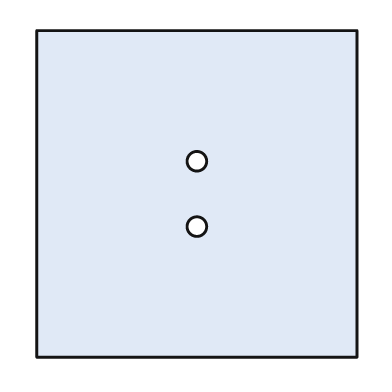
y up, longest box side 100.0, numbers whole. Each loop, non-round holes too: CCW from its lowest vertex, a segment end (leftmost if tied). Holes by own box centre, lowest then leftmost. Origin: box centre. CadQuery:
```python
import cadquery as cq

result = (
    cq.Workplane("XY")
    .moveTo(-49.0, -50.0)
    .lineTo(49.0, -50.0)
    .lineTo(49.0, 50.0)
    .lineTo(-49.0, 50.0)
    .close()
    .moveTo(0.0, -10.0)
    .circle(3.0)
    .moveTo(0.0, 10.0)
    .circle(3.0)
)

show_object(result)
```